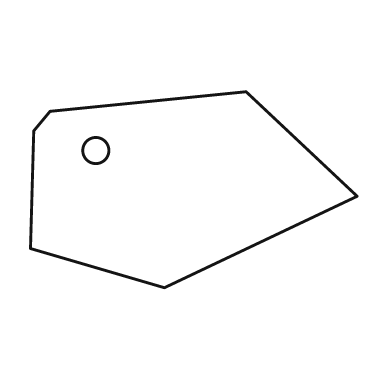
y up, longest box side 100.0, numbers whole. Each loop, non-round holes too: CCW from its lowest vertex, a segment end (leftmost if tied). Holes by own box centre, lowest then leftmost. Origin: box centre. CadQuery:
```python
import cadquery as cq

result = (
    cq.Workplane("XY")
    .moveTo(-9.0, -30.0)
    .lineTo(50.0, -2.0)
    .lineTo(16.0, 30.0)
    .lineTo(-44.0, 24.0)
    .lineTo(-49.0, 18.0)
    .lineTo(-50.0, -18.0)
    .close()
    .moveTo(-30.0, 12.0)
    .circle(4.0)
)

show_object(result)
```